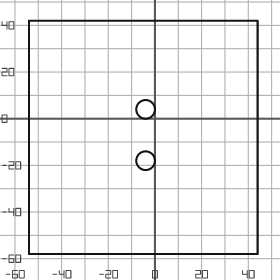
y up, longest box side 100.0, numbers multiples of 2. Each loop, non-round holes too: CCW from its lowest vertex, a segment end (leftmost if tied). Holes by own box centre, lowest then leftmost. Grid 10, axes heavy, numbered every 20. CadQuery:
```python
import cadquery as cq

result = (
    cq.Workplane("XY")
    .moveTo(-54.0, -58.0)
    .lineTo(44.0, -58.0)
    .lineTo(44.0, 42.0)
    .lineTo(-54.0, 42.0)
    .close()
    .moveTo(-4.0, -18.0)
    .circle(4.0)
    .moveTo(-4.0, 4.0)
    .circle(4.0)
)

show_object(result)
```